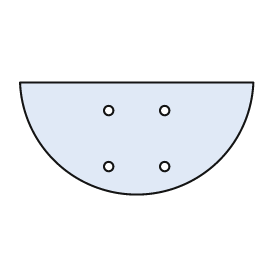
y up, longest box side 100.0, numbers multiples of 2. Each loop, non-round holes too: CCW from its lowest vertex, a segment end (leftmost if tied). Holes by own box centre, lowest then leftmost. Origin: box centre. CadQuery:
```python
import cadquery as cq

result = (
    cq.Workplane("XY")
    .moveTo(-50.0, 24.0)
    .threePointArc((0.0, -24.0), (50.0, 24.0))
    .close()
    .moveTo(-12.0, -12.0)
    .circle(2.0)
    .moveTo(12.0, -12.0)
    .circle(2.0)
    .moveTo(-12.0, 12.0)
    .circle(2.0)
    .moveTo(12.0, 12.0)
    .circle(2.0)
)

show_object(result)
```